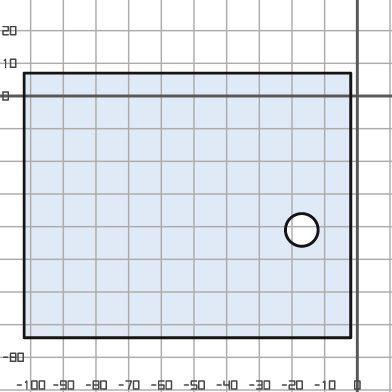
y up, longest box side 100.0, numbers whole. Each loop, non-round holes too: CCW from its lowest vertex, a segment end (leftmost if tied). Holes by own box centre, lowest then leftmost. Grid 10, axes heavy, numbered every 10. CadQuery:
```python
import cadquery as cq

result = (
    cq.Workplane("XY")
    .moveTo(-102.0, -74.0)
    .lineTo(-2.0, -74.0)
    .lineTo(-2.0, 7.0)
    .lineTo(-102.0, 7.0)
    .close()
    .moveTo(-17.0, -41.0)
    .circle(5.0)
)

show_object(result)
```